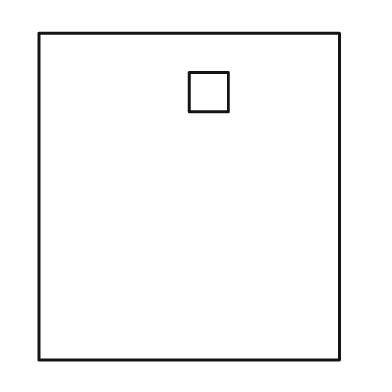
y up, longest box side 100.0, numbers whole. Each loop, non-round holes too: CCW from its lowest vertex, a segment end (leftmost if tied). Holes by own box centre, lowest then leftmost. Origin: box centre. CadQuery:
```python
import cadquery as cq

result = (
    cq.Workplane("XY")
    .moveTo(-46.0, -50.0)
    .lineTo(46.0, -50.0)
    .lineTo(46.0, 50.0)
    .lineTo(-46.0, 50.0)
    .close()
    .moveTo(0.0, 26.0)
    .lineTo(12.0, 26.0)
    .lineTo(12.0, 38.0)
    .lineTo(0.0, 38.0)
    .close()
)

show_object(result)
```